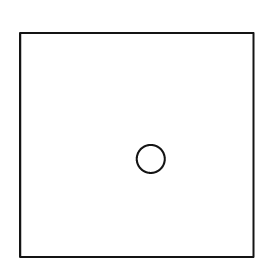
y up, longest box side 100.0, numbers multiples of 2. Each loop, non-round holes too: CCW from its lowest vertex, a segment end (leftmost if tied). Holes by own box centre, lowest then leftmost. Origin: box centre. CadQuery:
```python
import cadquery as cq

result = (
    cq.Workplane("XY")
    .moveTo(-50.0, -48.0)
    .lineTo(50.0, -48.0)
    .lineTo(50.0, 48.0)
    .lineTo(-50.0, 48.0)
    .close()
    .moveTo(6.0, -6.0)
    .circle(6.0)
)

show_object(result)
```